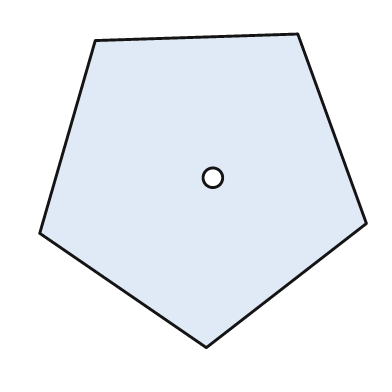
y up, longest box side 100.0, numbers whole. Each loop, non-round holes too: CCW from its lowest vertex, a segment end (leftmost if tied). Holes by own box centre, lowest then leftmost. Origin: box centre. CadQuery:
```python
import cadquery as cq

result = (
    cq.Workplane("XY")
    .moveTo(1.0, -48.0)
    .lineTo(50.0, -10.0)
    .lineTo(29.0, 48.0)
    .lineTo(-33.0, 46.0)
    .lineTo(-50.0, -13.0)
    .close()
    .moveTo(3.0, 4.0)
    .circle(3.0)
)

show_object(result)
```